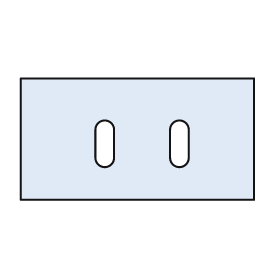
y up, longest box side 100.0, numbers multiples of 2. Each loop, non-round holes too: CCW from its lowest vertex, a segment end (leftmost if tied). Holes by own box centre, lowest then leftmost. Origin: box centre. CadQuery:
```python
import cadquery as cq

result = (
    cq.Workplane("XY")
    .moveTo(-50.0, -26.0)
    .lineTo(50.0, -26.0)
    .lineTo(50.0, 26.0)
    .lineTo(-50.0, 26.0)
    .close()
    .moveTo(-18.0, -8.0)
    .threePointArc((-14.0, -12.0), (-10.0, -8.0))
    .lineTo(-10.0, 4.0)
    .threePointArc((-14.0, 8.0), (-18.0, 4.0))
    .close()
    .moveTo(14.0, -8.0)
    .threePointArc((18.0, -12.0), (22.0, -8.0))
    .lineTo(22.0, 4.0)
    .threePointArc((18.0, 8.0), (14.0, 4.0))
    .close()
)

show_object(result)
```